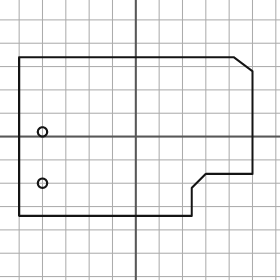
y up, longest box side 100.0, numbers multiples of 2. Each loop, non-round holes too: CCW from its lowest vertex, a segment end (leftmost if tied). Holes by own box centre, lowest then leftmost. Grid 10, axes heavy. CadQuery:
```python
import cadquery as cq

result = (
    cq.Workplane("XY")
    .moveTo(-50.0, -34.0)
    .lineTo(24.0, -34.0)
    .lineTo(24.0, -22.0)
    .lineTo(30.0, -16.0)
    .lineTo(50.0, -16.0)
    .lineTo(50.0, 28.0)
    .lineTo(42.0, 34.0)
    .lineTo(-50.0, 34.0)
    .close()
    .moveTo(-40.0, -20.0)
    .circle(2.0)
    .moveTo(-40.0, 2.0)
    .circle(2.0)
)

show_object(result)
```